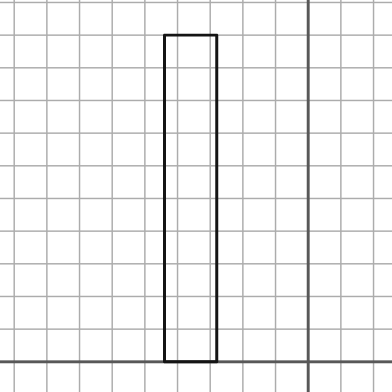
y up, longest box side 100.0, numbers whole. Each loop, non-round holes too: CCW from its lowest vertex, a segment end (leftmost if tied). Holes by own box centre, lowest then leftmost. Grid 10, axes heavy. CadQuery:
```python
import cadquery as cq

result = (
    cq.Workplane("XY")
    .moveTo(-44.0, 0.0)
    .lineTo(-28.0, 0.0)
    .lineTo(-28.0, 100.0)
    .lineTo(-44.0, 100.0)
    .close()
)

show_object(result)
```